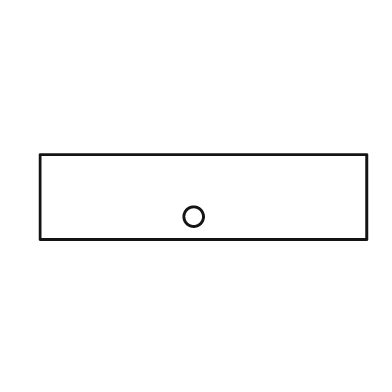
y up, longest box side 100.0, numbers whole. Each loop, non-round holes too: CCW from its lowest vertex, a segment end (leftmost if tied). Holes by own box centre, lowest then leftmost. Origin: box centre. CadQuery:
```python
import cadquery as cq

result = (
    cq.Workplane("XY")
    .moveTo(-50.0, -13.0)
    .lineTo(50.0, -13.0)
    .lineTo(50.0, 13.0)
    .lineTo(-50.0, 13.0)
    .close()
    .moveTo(-3.0, -6.0)
    .circle(3.0)
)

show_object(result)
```